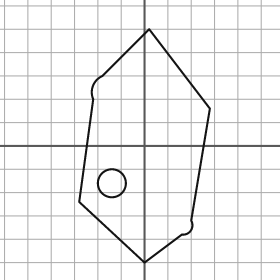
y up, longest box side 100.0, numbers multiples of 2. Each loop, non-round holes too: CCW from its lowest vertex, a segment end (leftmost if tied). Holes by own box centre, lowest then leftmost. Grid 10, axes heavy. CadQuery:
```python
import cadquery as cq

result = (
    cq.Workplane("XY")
    .moveTo(0.0, -50.0)
    .lineTo(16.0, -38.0)
    .threePointArc((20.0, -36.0), (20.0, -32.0))
    .lineTo(28.0, 16.0)
    .lineTo(2.0, 50.0)
    .lineTo(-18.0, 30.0)
    .threePointArc((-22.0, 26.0), (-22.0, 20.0))
    .lineTo(-28.0, -24.0)
    .close()
    .moveTo(-14.0, -16.0)
    .circle(6.0)
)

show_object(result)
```